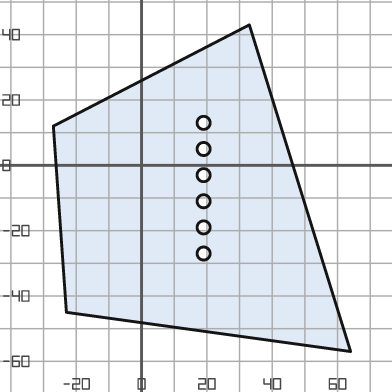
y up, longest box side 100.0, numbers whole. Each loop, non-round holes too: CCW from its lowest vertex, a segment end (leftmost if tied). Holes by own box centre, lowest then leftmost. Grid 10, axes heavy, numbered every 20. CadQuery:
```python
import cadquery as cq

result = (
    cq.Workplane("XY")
    .moveTo(64.0, -57.0)
    .lineTo(33.0, 43.0)
    .lineTo(-27.0, 12.0)
    .lineTo(-23.0, -45.0)
    .close()
    .moveTo(19.0, -27.0)
    .circle(2.0)
    .moveTo(19.0, -19.0)
    .circle(2.0)
    .moveTo(19.0, -11.0)
    .circle(2.0)
    .moveTo(19.0, -3.0)
    .circle(2.0)
    .moveTo(19.0, 5.0)
    .circle(2.0)
    .moveTo(19.0, 13.0)
    .circle(2.0)
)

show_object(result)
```